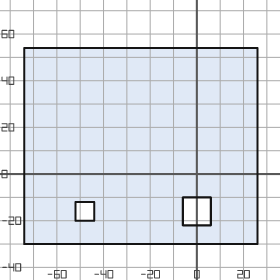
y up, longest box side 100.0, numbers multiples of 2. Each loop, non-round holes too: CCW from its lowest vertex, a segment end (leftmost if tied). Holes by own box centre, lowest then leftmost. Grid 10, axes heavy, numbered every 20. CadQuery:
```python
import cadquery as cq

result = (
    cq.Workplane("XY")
    .moveTo(-74.0, -30.0)
    .lineTo(26.0, -30.0)
    .lineTo(26.0, 54.0)
    .lineTo(-74.0, 54.0)
    .close()
    .moveTo(-52.0, -20.0)
    .lineTo(-44.0, -20.0)
    .lineTo(-44.0, -12.0)
    .lineTo(-52.0, -12.0)
    .close()
    .moveTo(-6.0, -22.0)
    .lineTo(6.0, -22.0)
    .lineTo(6.0, -10.0)
    .lineTo(-6.0, -10.0)
    .close()
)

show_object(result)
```